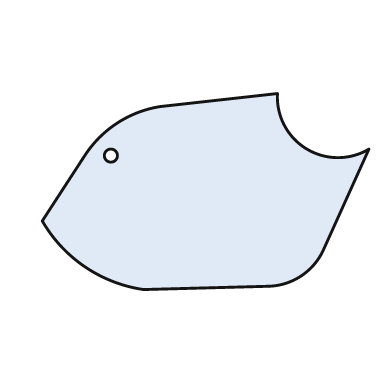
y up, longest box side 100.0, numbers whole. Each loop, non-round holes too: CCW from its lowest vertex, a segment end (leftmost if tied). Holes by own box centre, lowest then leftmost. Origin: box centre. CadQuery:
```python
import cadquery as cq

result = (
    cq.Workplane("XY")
    .moveTo(-19.0, -30.0)
    .lineTo(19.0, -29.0)
    .threePointArc((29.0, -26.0), (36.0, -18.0))
    .lineTo(50.0, 13.0)
    .threePointArc((31.0, 13.0), (22.0, 30.0))
    .lineTo(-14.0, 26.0)
    .threePointArc((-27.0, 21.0), (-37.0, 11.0))
    .lineTo(-50.0, -9.0)
    .threePointArc((-37.0, -23.0), (-19.0, -30.0))
    .close()
    .moveTo(-29.0, 11.0)
    .circle(2.0)
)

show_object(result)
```